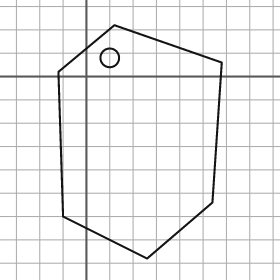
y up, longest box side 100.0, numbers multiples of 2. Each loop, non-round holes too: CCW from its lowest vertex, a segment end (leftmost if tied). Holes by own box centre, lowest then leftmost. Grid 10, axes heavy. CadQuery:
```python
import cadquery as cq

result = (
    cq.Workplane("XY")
    .moveTo(26.0, -78.0)
    .lineTo(54.0, -54.0)
    .lineTo(58.0, 6.0)
    .lineTo(12.0, 22.0)
    .lineTo(-12.0, 2.0)
    .lineTo(-10.0, -60.0)
    .close()
    .moveTo(10.0, 8.0)
    .circle(4.0)
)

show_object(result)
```